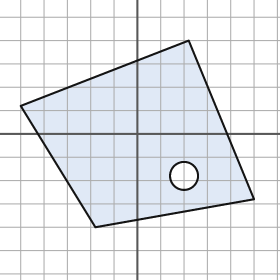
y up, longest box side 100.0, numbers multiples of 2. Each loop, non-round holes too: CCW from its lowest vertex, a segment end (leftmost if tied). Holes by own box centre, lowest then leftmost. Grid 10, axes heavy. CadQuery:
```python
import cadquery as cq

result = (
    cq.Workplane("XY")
    .moveTo(-18.0, -40.0)
    .lineTo(50.0, -28.0)
    .lineTo(22.0, 40.0)
    .lineTo(-50.0, 12.0)
    .close()
    .moveTo(20.0, -18.0)
    .circle(6.0)
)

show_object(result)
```